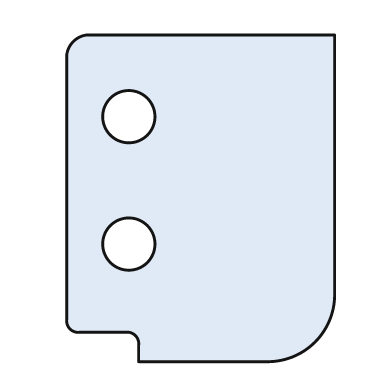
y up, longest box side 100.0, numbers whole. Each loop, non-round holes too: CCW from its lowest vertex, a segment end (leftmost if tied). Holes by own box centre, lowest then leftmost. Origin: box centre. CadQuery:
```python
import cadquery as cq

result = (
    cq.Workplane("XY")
    .moveTo(-19.0, -50.0)
    .lineTo(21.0, -50.0)
    .threePointArc((35.0, -44.0), (41.0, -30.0))
    .lineTo(41.0, 50.0)
    .lineTo(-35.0, 50.0)
    .threePointArc((-39.0, 48.0), (-41.0, 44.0))
    .lineTo(-41.0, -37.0)
    .threePointArc((-40.0, -40.0), (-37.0, -41.0))
    .lineTo(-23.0, -41.0)
    .threePointArc((-20.0, -42.0), (-19.0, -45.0))
    .close()
    .moveTo(-22.0, -14.0)
    .circle(8.0)
    .moveTo(-22.0, 25.0)
    .circle(8.0)
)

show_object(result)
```